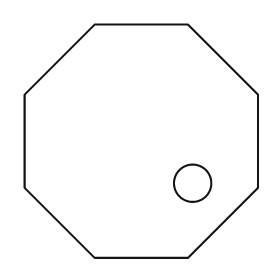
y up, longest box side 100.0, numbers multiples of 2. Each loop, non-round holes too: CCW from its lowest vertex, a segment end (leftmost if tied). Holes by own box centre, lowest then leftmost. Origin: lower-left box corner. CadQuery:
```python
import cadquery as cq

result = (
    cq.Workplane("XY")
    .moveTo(30.0, 0.0)
    .lineTo(70.0, 0.0)
    .lineTo(100.0, 30.0)
    .lineTo(100.0, 70.0)
    .lineTo(70.0, 100.0)
    .lineTo(30.0, 100.0)
    .lineTo(0.0, 70.0)
    .lineTo(0.0, 30.0)
    .close()
    .moveTo(72.0, 32.0)
    .circle(8.0)
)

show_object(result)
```